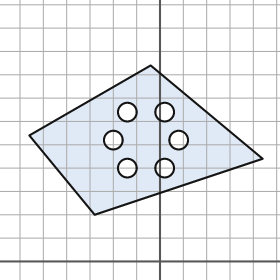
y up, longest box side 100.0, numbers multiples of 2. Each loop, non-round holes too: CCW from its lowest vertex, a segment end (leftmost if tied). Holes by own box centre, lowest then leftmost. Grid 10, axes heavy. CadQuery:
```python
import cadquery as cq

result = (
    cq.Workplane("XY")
    .moveTo(-28.0, 20.0)
    .lineTo(44.0, 44.0)
    .lineTo(-4.0, 84.0)
    .lineTo(-56.0, 54.0)
    .close()
    .moveTo(-14.0, 40.0)
    .circle(4.0)
    .moveTo(2.0, 40.0)
    .circle(4.0)
    .moveTo(-20.0, 52.0)
    .circle(4.0)
    .moveTo(8.0, 52.0)
    .circle(4.0)
    .moveTo(-14.0, 64.0)
    .circle(4.0)
    .moveTo(2.0, 64.0)
    .circle(4.0)
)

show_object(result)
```